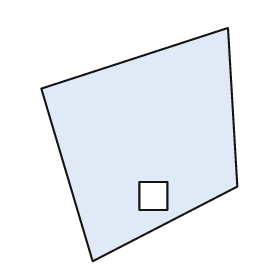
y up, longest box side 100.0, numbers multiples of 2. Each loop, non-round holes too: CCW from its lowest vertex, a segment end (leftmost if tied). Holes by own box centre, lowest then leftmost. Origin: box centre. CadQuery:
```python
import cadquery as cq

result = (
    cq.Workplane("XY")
    .moveTo(-20.0, -50.0)
    .lineTo(42.0, -18.0)
    .lineTo(38.0, 50.0)
    .lineTo(-42.0, 24.0)
    .close()
    .moveTo(0.0, -28.0)
    .lineTo(12.0, -28.0)
    .lineTo(12.0, -16.0)
    .lineTo(0.0, -16.0)
    .close()
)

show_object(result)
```